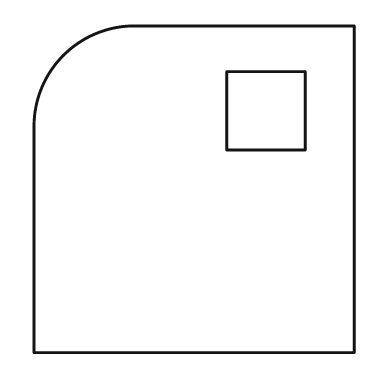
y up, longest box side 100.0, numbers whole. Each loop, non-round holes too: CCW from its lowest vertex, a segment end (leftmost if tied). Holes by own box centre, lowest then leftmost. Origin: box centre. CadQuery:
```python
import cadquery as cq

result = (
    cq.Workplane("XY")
    .moveTo(-49.0, -50.0)
    .lineTo(49.0, -50.0)
    .lineTo(49.0, 50.0)
    .lineTo(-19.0, 50.0)
    .threePointArc((-40.0, 41.0), (-49.0, 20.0))
    .close()
    .moveTo(10.0, 12.0)
    .lineTo(34.0, 12.0)
    .lineTo(34.0, 36.0)
    .lineTo(10.0, 36.0)
    .close()
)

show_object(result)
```